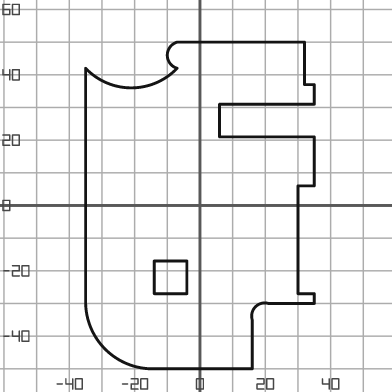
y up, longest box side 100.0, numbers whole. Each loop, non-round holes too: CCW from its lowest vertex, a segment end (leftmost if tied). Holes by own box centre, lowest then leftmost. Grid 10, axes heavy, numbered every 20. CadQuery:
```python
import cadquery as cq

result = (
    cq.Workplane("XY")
    .moveTo(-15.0, -50.0)
    .lineTo(16.0, -50.0)
    .lineTo(16.0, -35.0)
    .threePointArc((17.0, -31.0), (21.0, -30.0))
    .lineTo(35.0, -30.0)
    .lineTo(35.0, -27.0)
    .lineTo(30.0, -27.0)
    .lineTo(30.0, 6.0)
    .lineTo(35.0, 6.0)
    .lineTo(35.0, 21.0)
    .lineTo(6.0, 21.0)
    .lineTo(6.0, 31.0)
    .lineTo(35.0, 31.0)
    .lineTo(35.0, 37.0)
    .lineTo(32.0, 37.0)
    .lineTo(32.0, 50.0)
    .lineTo(-7.0, 50.0)
    .threePointArc((-10.0, 46.0), (-7.0, 42.0))
    .threePointArc((-21.0, 36.0), (-35.0, 42.0))
    .lineTo(-35.0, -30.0)
    .threePointArc((-29.0, -44.0), (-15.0, -50.0))
    .close()
    .moveTo(-14.0, -27.0)
    .lineTo(-4.0, -27.0)
    .lineTo(-4.0, -17.0)
    .lineTo(-14.0, -17.0)
    .close()
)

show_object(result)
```